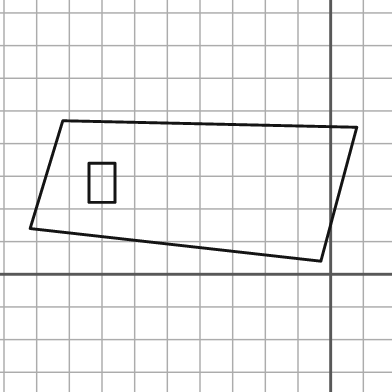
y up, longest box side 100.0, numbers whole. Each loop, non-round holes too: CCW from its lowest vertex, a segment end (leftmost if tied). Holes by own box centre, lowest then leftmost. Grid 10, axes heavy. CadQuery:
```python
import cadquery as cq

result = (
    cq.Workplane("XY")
    .moveTo(-3.0, 4.0)
    .lineTo(8.0, 45.0)
    .lineTo(-82.0, 47.0)
    .lineTo(-92.0, 14.0)
    .close()
    .moveTo(-74.0, 22.0)
    .lineTo(-66.0, 22.0)
    .lineTo(-66.0, 34.0)
    .lineTo(-74.0, 34.0)
    .close()
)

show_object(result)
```